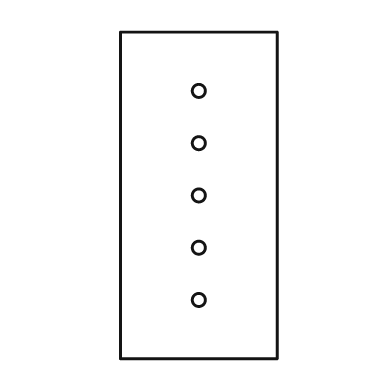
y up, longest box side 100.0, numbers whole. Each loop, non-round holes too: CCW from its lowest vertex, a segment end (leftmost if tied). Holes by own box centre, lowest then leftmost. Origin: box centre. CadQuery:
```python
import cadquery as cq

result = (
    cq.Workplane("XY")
    .moveTo(-24.0, -50.0)
    .lineTo(24.0, -50.0)
    .lineTo(24.0, 50.0)
    .lineTo(-24.0, 50.0)
    .close()
    .moveTo(0.0, -32.0)
    .circle(2.0)
    .moveTo(0.0, -16.0)
    .circle(2.0)
    .moveTo(0.0, 0.0)
    .circle(2.0)
    .moveTo(0.0, 16.0)
    .circle(2.0)
    .moveTo(0.0, 32.0)
    .circle(2.0)
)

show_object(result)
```